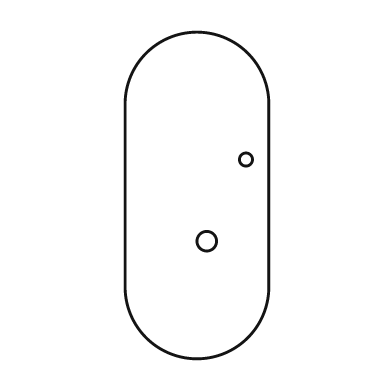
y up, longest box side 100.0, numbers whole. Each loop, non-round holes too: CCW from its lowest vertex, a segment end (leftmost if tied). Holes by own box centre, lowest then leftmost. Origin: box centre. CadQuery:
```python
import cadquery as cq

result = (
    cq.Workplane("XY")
    .moveTo(-22.0, -28.0)
    .threePointArc((0.0, -50.0), (22.0, -28.0))
    .lineTo(22.0, 28.0)
    .threePointArc((0.0, 50.0), (-22.0, 28.0))
    .close()
    .moveTo(3.0, -14.0)
    .circle(3.0)
    .moveTo(15.0, 11.0)
    .circle(2.0)
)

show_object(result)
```